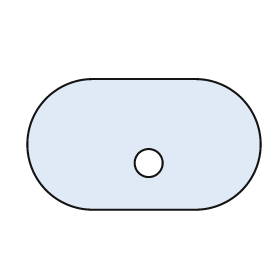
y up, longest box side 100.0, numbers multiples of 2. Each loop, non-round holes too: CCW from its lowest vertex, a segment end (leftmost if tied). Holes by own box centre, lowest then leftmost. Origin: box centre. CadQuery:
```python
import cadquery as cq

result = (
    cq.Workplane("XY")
    .moveTo(-22.0, -28.0)
    .lineTo(22.0, -28.0)
    .threePointArc((50.0, 0.0), (22.0, 28.0))
    .lineTo(-22.0, 28.0)
    .threePointArc((-50.0, 0.0), (-22.0, -28.0))
    .close()
    .moveTo(2.0, -8.0)
    .circle(6.0)
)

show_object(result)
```